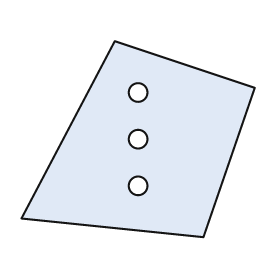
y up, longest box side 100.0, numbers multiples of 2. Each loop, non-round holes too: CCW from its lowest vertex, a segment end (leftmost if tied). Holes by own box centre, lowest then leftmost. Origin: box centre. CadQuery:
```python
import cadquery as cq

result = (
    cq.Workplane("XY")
    .moveTo(28.0, -42.0)
    .lineTo(50.0, 22.0)
    .lineTo(-10.0, 42.0)
    .lineTo(-50.0, -34.0)
    .close()
    .moveTo(0.0, -20.0)
    .circle(4.0)
    .moveTo(0.0, 0.0)
    .circle(4.0)
    .moveTo(0.0, 20.0)
    .circle(4.0)
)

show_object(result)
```